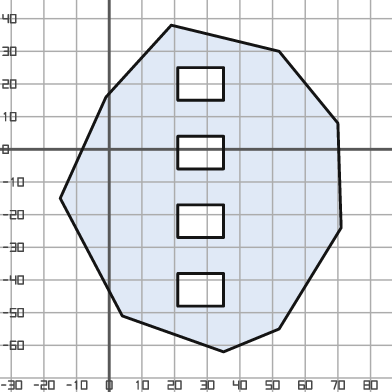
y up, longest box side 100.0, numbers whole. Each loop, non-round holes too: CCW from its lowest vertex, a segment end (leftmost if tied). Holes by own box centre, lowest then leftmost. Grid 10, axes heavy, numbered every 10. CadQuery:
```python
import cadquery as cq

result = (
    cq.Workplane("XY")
    .moveTo(35.0, -62.0)
    .lineTo(52.0, -55.0)
    .lineTo(71.0, -24.0)
    .lineTo(70.0, 8.0)
    .lineTo(52.0, 30.0)
    .lineTo(19.0, 38.0)
    .lineTo(-1.0, 16.0)
    .lineTo(-15.0, -15.0)
    .lineTo(4.0, -51.0)
    .close()
    .moveTo(21.0, -48.0)
    .lineTo(35.0, -48.0)
    .lineTo(35.0, -38.0)
    .lineTo(21.0, -38.0)
    .close()
    .moveTo(21.0, -27.0)
    .lineTo(35.0, -27.0)
    .lineTo(35.0, -17.0)
    .lineTo(21.0, -17.0)
    .close()
    .moveTo(21.0, -6.0)
    .lineTo(35.0, -6.0)
    .lineTo(35.0, 4.0)
    .lineTo(21.0, 4.0)
    .close()
    .moveTo(21.0, 15.0)
    .lineTo(35.0, 15.0)
    .lineTo(35.0, 25.0)
    .lineTo(21.0, 25.0)
    .close()
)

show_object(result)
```